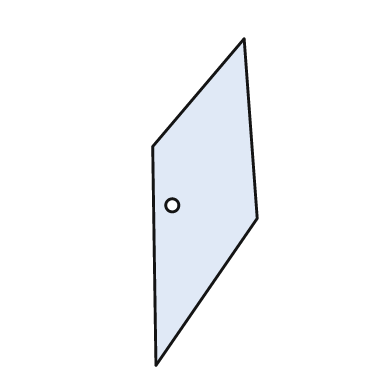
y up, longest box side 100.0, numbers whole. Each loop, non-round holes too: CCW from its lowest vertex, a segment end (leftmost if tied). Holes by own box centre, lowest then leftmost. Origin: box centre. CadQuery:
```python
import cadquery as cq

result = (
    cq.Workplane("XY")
    .moveTo(-15.0, -50.0)
    .lineTo(16.0, -5.0)
    .lineTo(12.0, 50.0)
    .lineTo(-16.0, 17.0)
    .close()
    .moveTo(-10.0, -1.0)
    .circle(2.0)
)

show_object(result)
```